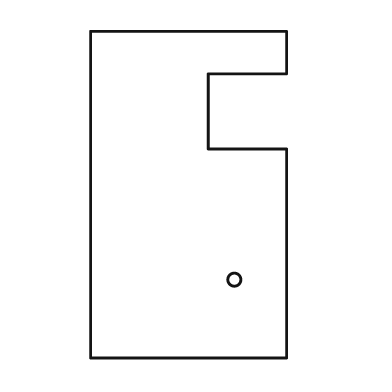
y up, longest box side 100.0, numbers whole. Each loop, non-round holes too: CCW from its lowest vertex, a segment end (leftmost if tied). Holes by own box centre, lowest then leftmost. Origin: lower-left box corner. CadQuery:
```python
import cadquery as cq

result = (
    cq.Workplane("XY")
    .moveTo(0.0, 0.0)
    .lineTo(60.0, 0.0)
    .lineTo(60.0, 64.0)
    .lineTo(36.0, 64.0)
    .lineTo(36.0, 87.0)
    .lineTo(60.0, 87.0)
    .lineTo(60.0, 100.0)
    .lineTo(0.0, 100.0)
    .close()
    .moveTo(44.0, 24.0)
    .circle(2.0)
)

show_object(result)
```